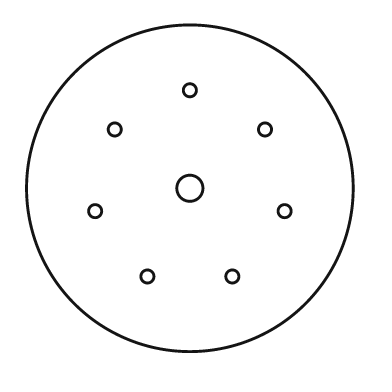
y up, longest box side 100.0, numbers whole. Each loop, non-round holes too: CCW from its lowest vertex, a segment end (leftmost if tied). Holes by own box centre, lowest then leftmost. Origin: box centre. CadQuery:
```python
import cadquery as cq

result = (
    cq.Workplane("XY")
    .moveTo(0.0, 0.0)
    .circle(50.0)
    .moveTo(-13.0, -27.0)
    .circle(2.0)
    .moveTo(13.0, -27.0)
    .circle(2.0)
    .moveTo(-29.0, -7.0)
    .circle(2.0)
    .moveTo(29.0, -7.0)
    .circle(2.0)
    .moveTo(0.0, 0.0)
    .circle(4.0)
    .moveTo(-23.0, 18.0)
    .circle(2.0)
    .moveTo(23.0, 18.0)
    .circle(2.0)
    .moveTo(0.0, 30.0)
    .circle(2.0)
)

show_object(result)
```